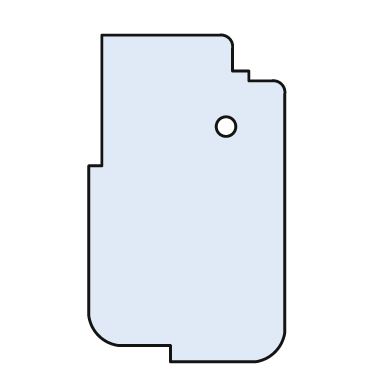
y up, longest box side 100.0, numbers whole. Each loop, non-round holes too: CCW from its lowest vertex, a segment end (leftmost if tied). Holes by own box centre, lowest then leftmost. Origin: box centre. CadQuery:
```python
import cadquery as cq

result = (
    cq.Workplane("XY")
    .moveTo(-5.0, -50.0)
    .lineTo(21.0, -50.0)
    .threePointArc((27.0, -47.0), (30.0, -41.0))
    .lineTo(30.0, 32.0)
    .threePointArc((29.0, 35.0), (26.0, 36.0))
    .lineTo(19.0, 36.0)
    .lineTo(19.0, 39.0)
    .lineTo(14.0, 39.0)
    .lineTo(14.0, 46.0)
    .threePointArc((13.0, 49.0), (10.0, 50.0))
    .lineTo(-26.0, 50.0)
    .lineTo(-26.0, 10.0)
    .lineTo(-30.0, 10.0)
    .lineTo(-30.0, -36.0)
    .threePointArc((-27.0, -42.0), (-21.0, -45.0))
    .lineTo(-5.0, -45.0)
    .close()
    .moveTo(12.0, 22.0)
    .circle(3.0)
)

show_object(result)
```